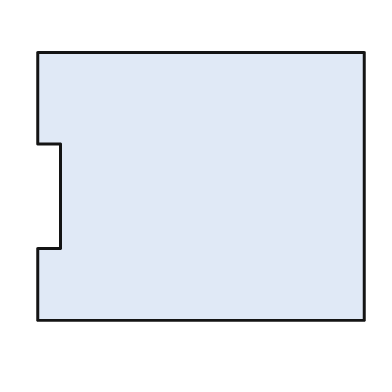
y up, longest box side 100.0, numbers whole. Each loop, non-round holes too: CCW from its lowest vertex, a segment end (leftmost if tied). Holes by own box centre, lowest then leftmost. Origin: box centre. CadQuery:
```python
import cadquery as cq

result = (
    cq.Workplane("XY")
    .moveTo(-50.0, -41.0)
    .lineTo(50.0, -41.0)
    .lineTo(50.0, 41.0)
    .lineTo(-50.0, 41.0)
    .lineTo(-50.0, 13.0)
    .lineTo(-43.0, 13.0)
    .lineTo(-43.0, -19.0)
    .lineTo(-50.0, -19.0)
    .close()
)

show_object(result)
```